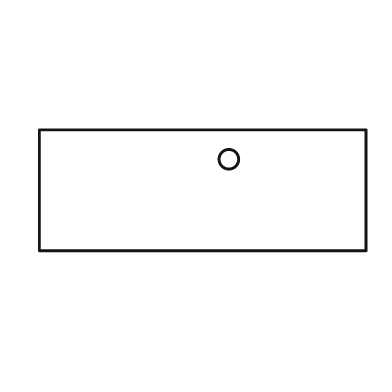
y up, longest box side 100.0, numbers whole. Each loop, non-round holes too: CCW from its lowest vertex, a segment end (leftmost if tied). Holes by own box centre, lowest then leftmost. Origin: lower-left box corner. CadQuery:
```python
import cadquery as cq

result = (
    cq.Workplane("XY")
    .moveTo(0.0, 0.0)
    .lineTo(100.0, 0.0)
    .lineTo(100.0, 37.0)
    .lineTo(0.0, 37.0)
    .close()
    .moveTo(58.0, 28.0)
    .circle(3.0)
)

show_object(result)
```